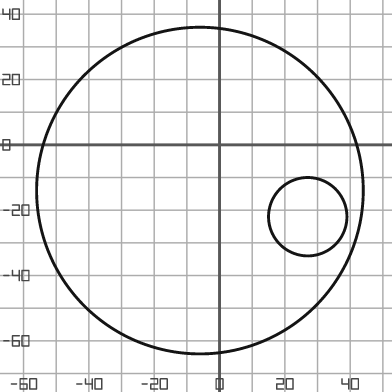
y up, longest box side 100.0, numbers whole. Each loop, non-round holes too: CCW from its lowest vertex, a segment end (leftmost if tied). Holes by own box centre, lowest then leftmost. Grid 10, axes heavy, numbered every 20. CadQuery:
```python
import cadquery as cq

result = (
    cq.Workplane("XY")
    .moveTo(-6.0, -14.0)
    .circle(50.0)
    .moveTo(27.0, -22.0)
    .circle(12.0)
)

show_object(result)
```